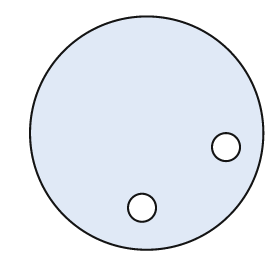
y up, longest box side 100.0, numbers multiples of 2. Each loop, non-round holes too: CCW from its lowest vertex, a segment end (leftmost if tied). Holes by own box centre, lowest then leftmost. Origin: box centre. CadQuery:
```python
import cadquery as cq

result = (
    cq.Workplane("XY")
    .moveTo(0.0, 0.0)
    .circle(50.0)
    .moveTo(-2.0, -32.0)
    .circle(6.0)
    .moveTo(34.0, -6.0)
    .circle(6.0)
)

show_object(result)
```